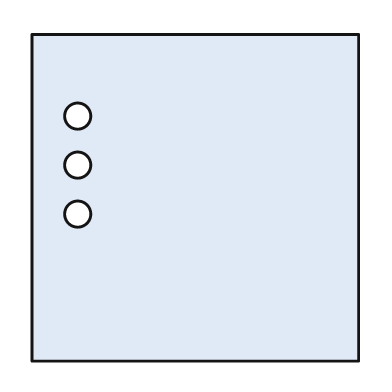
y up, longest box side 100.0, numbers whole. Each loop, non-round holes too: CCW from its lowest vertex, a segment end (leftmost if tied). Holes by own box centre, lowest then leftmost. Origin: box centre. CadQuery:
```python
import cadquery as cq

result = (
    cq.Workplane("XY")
    .moveTo(-50.0, -50.0)
    .lineTo(50.0, -50.0)
    .lineTo(50.0, 50.0)
    .lineTo(-50.0, 50.0)
    .close()
    .moveTo(-36.0, -5.0)
    .circle(4.0)
    .moveTo(-36.0, 10.0)
    .circle(4.0)
    .moveTo(-36.0, 25.0)
    .circle(4.0)
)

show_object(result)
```